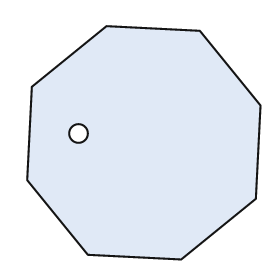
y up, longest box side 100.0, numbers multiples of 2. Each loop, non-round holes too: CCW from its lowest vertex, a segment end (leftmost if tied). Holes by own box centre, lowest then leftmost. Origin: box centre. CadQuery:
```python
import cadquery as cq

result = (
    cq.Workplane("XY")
    .moveTo(16.0, -50.0)
    .lineTo(48.0, -24.0)
    .lineTo(50.0, 16.0)
    .lineTo(24.0, 48.0)
    .lineTo(-16.0, 50.0)
    .lineTo(-48.0, 24.0)
    .lineTo(-50.0, -16.0)
    .lineTo(-24.0, -48.0)
    .close()
    .moveTo(-28.0, 4.0)
    .circle(4.0)
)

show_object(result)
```